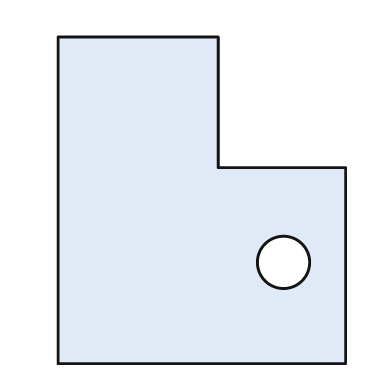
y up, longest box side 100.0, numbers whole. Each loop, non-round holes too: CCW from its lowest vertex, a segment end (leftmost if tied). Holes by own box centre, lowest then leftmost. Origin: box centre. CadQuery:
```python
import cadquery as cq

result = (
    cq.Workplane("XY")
    .moveTo(-44.0, -50.0)
    .lineTo(44.0, -50.0)
    .lineTo(44.0, 10.0)
    .lineTo(5.0, 10.0)
    .lineTo(5.0, 50.0)
    .lineTo(-44.0, 50.0)
    .close()
    .moveTo(25.0, -19.0)
    .circle(8.0)
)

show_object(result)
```